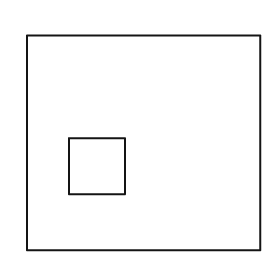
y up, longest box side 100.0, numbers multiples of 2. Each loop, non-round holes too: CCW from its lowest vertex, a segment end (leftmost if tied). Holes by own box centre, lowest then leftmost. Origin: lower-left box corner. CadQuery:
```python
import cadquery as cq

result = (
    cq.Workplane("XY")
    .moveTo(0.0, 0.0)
    .lineTo(100.0, 0.0)
    .lineTo(100.0, 92.0)
    .lineTo(0.0, 92.0)
    .close()
    .moveTo(18.0, 24.0)
    .lineTo(42.0, 24.0)
    .lineTo(42.0, 48.0)
    .lineTo(18.0, 48.0)
    .close()
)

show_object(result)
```